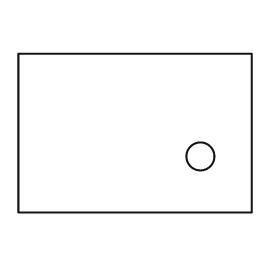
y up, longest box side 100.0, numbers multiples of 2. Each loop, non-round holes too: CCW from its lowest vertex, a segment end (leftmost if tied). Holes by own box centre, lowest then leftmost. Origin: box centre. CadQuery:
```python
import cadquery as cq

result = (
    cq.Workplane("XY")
    .moveTo(-50.0, -34.0)
    .lineTo(50.0, -34.0)
    .lineTo(50.0, 34.0)
    .lineTo(-50.0, 34.0)
    .close()
    .moveTo(28.0, -10.0)
    .circle(6.0)
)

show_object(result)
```